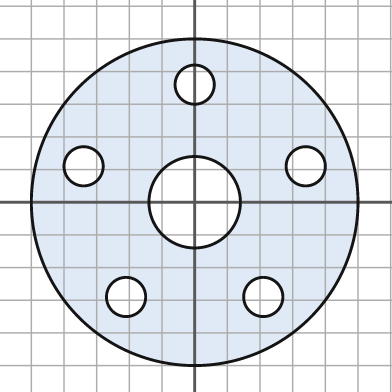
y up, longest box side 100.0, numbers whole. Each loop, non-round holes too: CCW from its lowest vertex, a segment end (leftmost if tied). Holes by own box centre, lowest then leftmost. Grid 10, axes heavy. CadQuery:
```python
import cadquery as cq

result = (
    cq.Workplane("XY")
    .moveTo(0.0, 0.0)
    .circle(50.0)
    .moveTo(-21.0, -29.0)
    .circle(6.0)
    .moveTo(21.0, -29.0)
    .circle(6.0)
    .moveTo(0.0, 0.0)
    .circle(14.0)
    .moveTo(-34.0, 11.0)
    .circle(6.0)
    .moveTo(34.0, 11.0)
    .circle(6.0)
    .moveTo(0.0, 36.0)
    .circle(6.0)
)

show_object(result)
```